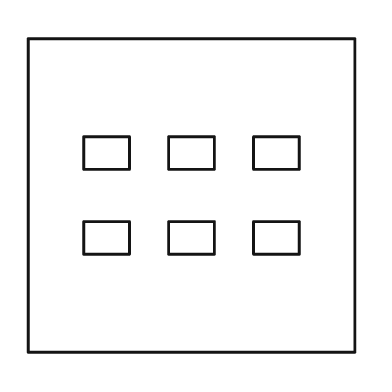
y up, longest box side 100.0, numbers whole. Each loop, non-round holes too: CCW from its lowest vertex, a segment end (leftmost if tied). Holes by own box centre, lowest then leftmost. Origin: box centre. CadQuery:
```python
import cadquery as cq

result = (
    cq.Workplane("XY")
    .moveTo(-50.0, -48.0)
    .lineTo(50.0, -48.0)
    .lineTo(50.0, 48.0)
    .lineTo(-50.0, 48.0)
    .close()
    .moveTo(-33.0, -18.0)
    .lineTo(-19.0, -18.0)
    .lineTo(-19.0, -8.0)
    .lineTo(-33.0, -8.0)
    .close()
    .moveTo(-7.0, -18.0)
    .lineTo(7.0, -18.0)
    .lineTo(7.0, -8.0)
    .lineTo(-7.0, -8.0)
    .close()
    .moveTo(19.0, -18.0)
    .lineTo(33.0, -18.0)
    .lineTo(33.0, -8.0)
    .lineTo(19.0, -8.0)
    .close()
    .moveTo(-33.0, 8.0)
    .lineTo(-19.0, 8.0)
    .lineTo(-19.0, 18.0)
    .lineTo(-33.0, 18.0)
    .close()
    .moveTo(-7.0, 8.0)
    .lineTo(7.0, 8.0)
    .lineTo(7.0, 18.0)
    .lineTo(-7.0, 18.0)
    .close()
    .moveTo(19.0, 8.0)
    .lineTo(33.0, 8.0)
    .lineTo(33.0, 18.0)
    .lineTo(19.0, 18.0)
    .close()
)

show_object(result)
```